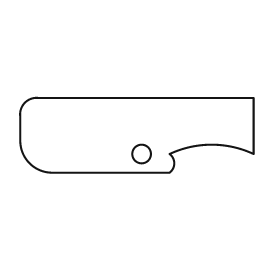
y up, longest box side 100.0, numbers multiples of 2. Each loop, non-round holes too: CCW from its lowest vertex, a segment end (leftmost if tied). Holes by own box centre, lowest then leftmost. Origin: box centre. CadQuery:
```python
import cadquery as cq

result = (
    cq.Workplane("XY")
    .moveTo(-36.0, -16.0)
    .lineTo(14.0, -16.0)
    .threePointArc((16.0, -12.0), (14.0, -8.0))
    .threePointArc((32.0, -4.0), (50.0, -8.0))
    .lineTo(50.0, 16.0)
    .lineTo(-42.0, 16.0)
    .threePointArc((-48.0, 14.0), (-50.0, 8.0))
    .lineTo(-50.0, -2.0)
    .threePointArc((-46.0, -12.0), (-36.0, -16.0))
    .close()
    .moveTo(2.0, -8.0)
    .circle(4.0)
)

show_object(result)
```